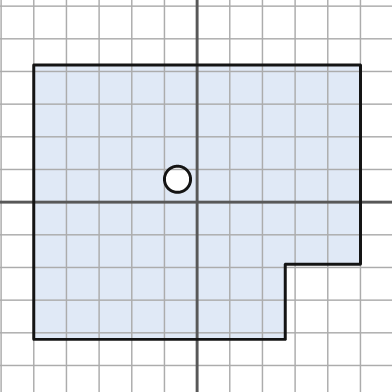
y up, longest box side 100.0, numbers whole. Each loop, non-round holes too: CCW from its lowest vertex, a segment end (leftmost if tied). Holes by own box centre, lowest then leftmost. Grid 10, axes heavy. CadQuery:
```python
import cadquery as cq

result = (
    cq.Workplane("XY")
    .moveTo(-50.0, -42.0)
    .lineTo(27.0, -42.0)
    .lineTo(27.0, -19.0)
    .lineTo(50.0, -19.0)
    .lineTo(50.0, 42.0)
    .lineTo(-50.0, 42.0)
    .close()
    .moveTo(-6.0, 7.0)
    .circle(4.0)
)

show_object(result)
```